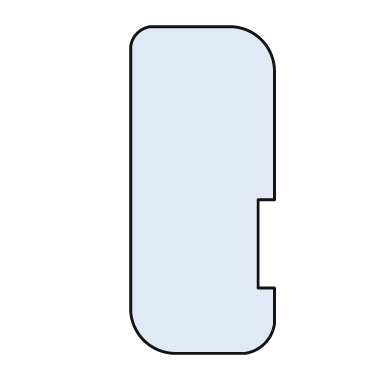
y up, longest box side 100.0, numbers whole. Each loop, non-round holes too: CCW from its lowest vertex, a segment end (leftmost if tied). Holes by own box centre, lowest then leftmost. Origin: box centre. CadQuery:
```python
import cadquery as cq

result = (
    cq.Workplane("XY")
    .moveTo(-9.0, -50.0)
    .lineTo(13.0, -50.0)
    .threePointArc((19.0, -47.0), (22.0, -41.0))
    .lineTo(22.0, -30.0)
    .lineTo(17.0, -30.0)
    .lineTo(17.0, -3.0)
    .lineTo(22.0, -3.0)
    .lineTo(22.0, 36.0)
    .threePointArc((18.0, 46.0), (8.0, 50.0))
    .lineTo(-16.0, 50.0)
    .threePointArc((-20.0, 48.0), (-22.0, 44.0))
    .lineTo(-22.0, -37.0)
    .threePointArc((-18.0, -46.0), (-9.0, -50.0))
    .close()
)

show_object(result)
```